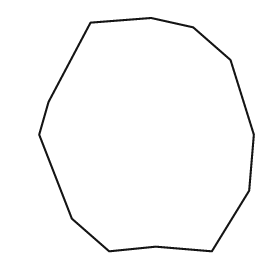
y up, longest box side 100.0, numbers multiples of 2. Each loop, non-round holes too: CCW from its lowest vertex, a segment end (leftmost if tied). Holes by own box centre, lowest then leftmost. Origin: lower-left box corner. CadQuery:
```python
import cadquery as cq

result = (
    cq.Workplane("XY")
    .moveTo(30.0, 0.0)
    .lineTo(50.0, 2.0)
    .lineTo(74.0, 0.0)
    .lineTo(90.0, 26.0)
    .lineTo(92.0, 50.0)
    .lineTo(82.0, 82.0)
    .lineTo(66.0, 96.0)
    .lineTo(48.0, 100.0)
    .lineTo(22.0, 98.0)
    .lineTo(4.0, 64.0)
    .lineTo(0.0, 50.0)
    .lineTo(14.0, 14.0)
    .close()
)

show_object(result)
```